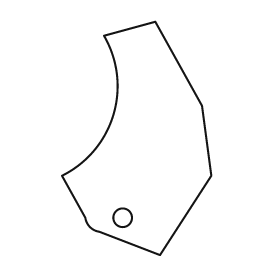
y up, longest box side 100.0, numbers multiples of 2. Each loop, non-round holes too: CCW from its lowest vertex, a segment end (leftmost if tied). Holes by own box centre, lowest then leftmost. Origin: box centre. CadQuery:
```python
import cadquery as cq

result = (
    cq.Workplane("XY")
    .moveTo(10.0, -50.0)
    .lineTo(32.0, -16.0)
    .lineTo(28.0, 14.0)
    .lineTo(8.0, 50.0)
    .lineTo(-14.0, 44.0)
    .threePointArc((-10.0, 10.0), (-32.0, -16.0))
    .lineTo(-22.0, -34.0)
    .threePointArc((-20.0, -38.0), (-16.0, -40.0))
    .close()
    .moveTo(-6.0, -34.0)
    .circle(4.0)
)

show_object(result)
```